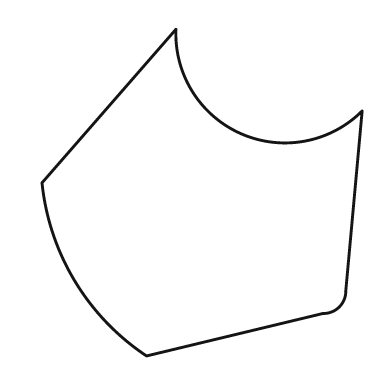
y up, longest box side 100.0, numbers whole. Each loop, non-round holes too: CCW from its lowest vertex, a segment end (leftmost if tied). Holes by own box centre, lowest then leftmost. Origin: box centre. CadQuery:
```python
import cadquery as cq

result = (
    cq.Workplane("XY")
    .moveTo(-17.0, -50.0)
    .lineTo(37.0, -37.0)
    .threePointArc((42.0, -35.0), (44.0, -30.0))
    .lineTo(49.0, 25.0)
    .threePointArc((12.0, 18.0), (-8.0, 50.0))
    .lineTo(-49.0, 3.0)
    .threePointArc((-39.0, -27.0), (-17.0, -50.0))
    .close()
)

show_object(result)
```